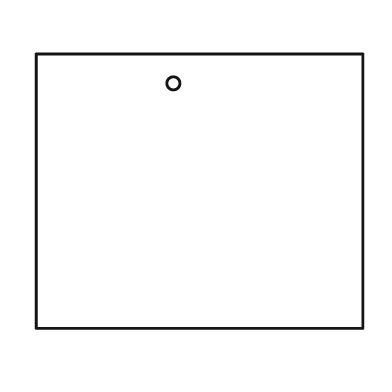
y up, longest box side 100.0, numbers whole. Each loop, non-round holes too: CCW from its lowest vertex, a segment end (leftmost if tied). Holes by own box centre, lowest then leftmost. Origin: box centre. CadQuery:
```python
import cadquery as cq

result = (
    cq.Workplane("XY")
    .moveTo(-50.0, -42.0)
    .lineTo(50.0, -42.0)
    .lineTo(50.0, 42.0)
    .lineTo(-50.0, 42.0)
    .close()
    .moveTo(-8.0, 33.0)
    .circle(2.0)
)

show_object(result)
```